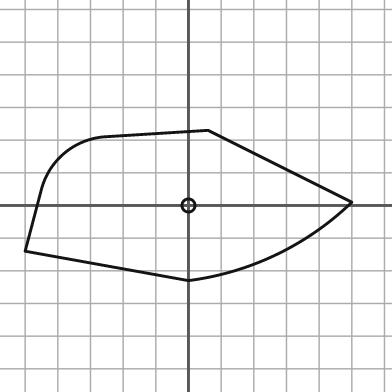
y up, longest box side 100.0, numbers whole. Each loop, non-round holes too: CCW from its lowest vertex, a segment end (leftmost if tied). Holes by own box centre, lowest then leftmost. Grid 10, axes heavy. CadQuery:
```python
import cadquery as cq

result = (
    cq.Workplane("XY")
    .moveTo(0.0, -23.0)
    .threePointArc((27.0, -15.0), (50.0, 1.0))
    .lineTo(6.0, 23.0)
    .lineTo(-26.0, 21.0)
    .threePointArc((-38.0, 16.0), (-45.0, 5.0))
    .lineTo(-50.0, -14.0)
    .close()
    .moveTo(0.0, 0.0)
    .circle(2.0)
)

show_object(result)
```